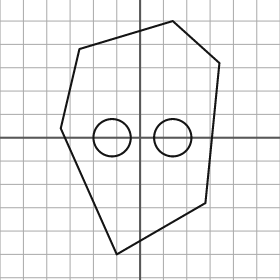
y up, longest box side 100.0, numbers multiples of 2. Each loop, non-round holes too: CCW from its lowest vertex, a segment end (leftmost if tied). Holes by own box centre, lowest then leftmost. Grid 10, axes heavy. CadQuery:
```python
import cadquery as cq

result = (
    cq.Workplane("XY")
    .moveTo(-10.0, -50.0)
    .lineTo(28.0, -28.0)
    .lineTo(34.0, 32.0)
    .lineTo(14.0, 50.0)
    .lineTo(-26.0, 38.0)
    .lineTo(-34.0, 4.0)
    .close()
    .moveTo(-12.0, 0.0)
    .circle(8.0)
    .moveTo(14.0, 0.0)
    .circle(8.0)
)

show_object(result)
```